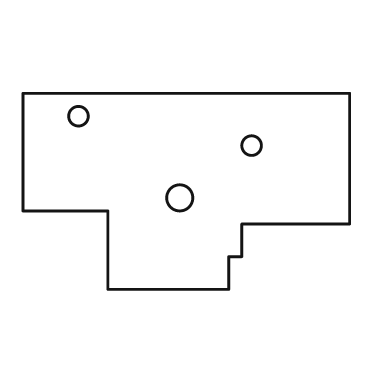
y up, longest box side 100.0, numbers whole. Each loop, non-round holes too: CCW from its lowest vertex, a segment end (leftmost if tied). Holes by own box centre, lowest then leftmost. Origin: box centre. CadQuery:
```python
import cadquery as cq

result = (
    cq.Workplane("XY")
    .moveTo(-24.0, -30.0)
    .lineTo(13.0, -30.0)
    .lineTo(13.0, -20.0)
    .lineTo(17.0, -20.0)
    .lineTo(17.0, -10.0)
    .lineTo(50.0, -10.0)
    .lineTo(50.0, 30.0)
    .lineTo(-50.0, 30.0)
    .lineTo(-50.0, -6.0)
    .lineTo(-24.0, -6.0)
    .close()
    .moveTo(-2.0, -2.0)
    .circle(4.0)
    .moveTo(20.0, 14.0)
    .circle(3.0)
    .moveTo(-33.0, 23.0)
    .circle(3.0)
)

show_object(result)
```